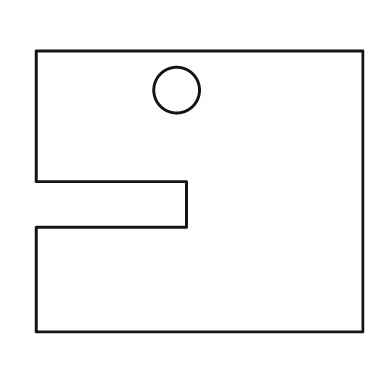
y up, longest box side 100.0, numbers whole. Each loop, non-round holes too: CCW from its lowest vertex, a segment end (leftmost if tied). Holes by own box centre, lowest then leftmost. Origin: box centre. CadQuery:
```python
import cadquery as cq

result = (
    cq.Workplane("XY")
    .moveTo(-50.0, -43.0)
    .lineTo(50.0, -43.0)
    .lineTo(50.0, 43.0)
    .lineTo(-50.0, 43.0)
    .lineTo(-50.0, 3.0)
    .lineTo(-4.0, 3.0)
    .lineTo(-4.0, -11.0)
    .lineTo(-50.0, -11.0)
    .close()
    .moveTo(-7.0, 31.0)
    .circle(7.0)
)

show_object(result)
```